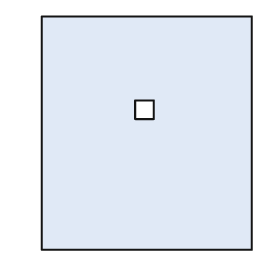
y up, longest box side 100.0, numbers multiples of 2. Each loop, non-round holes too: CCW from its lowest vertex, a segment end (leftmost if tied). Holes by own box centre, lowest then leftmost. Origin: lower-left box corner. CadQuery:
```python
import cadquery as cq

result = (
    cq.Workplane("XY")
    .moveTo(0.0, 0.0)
    .lineTo(90.0, 0.0)
    .lineTo(90.0, 100.0)
    .lineTo(0.0, 100.0)
    .close()
    .moveTo(40.0, 56.0)
    .lineTo(48.0, 56.0)
    .lineTo(48.0, 64.0)
    .lineTo(40.0, 64.0)
    .close()
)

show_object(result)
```